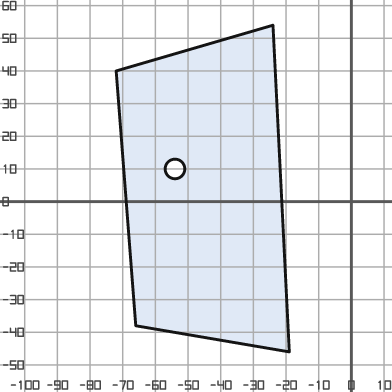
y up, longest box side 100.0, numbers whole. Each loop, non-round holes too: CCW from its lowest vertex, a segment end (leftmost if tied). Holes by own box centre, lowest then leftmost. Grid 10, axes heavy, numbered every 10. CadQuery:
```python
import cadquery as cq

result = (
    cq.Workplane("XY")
    .moveTo(-19.0, -46.0)
    .lineTo(-24.0, 54.0)
    .lineTo(-72.0, 40.0)
    .lineTo(-66.0, -38.0)
    .close()
    .moveTo(-54.0, 10.0)
    .circle(3.0)
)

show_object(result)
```